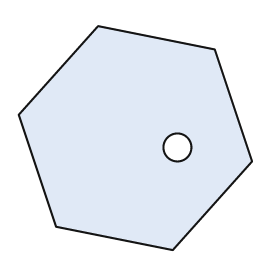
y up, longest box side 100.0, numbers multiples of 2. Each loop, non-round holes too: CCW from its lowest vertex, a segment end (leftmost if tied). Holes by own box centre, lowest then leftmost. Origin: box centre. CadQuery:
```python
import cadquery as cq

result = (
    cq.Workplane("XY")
    .moveTo(16.0, -48.0)
    .lineTo(50.0, -10.0)
    .lineTo(34.0, 38.0)
    .lineTo(-16.0, 48.0)
    .lineTo(-50.0, 10.0)
    .lineTo(-34.0, -38.0)
    .close()
    .moveTo(18.0, -4.0)
    .circle(6.0)
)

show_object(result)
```